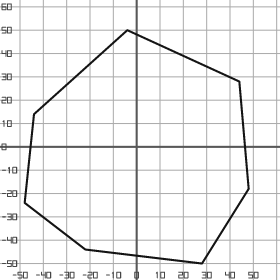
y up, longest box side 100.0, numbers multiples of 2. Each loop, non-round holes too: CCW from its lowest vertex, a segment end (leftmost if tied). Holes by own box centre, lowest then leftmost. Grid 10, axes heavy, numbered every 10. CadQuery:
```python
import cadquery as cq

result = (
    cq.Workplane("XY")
    .moveTo(28.0, -50.0)
    .lineTo(48.0, -18.0)
    .lineTo(44.0, 28.0)
    .lineTo(-4.0, 50.0)
    .lineTo(-44.0, 14.0)
    .lineTo(-48.0, -24.0)
    .lineTo(-22.0, -44.0)
    .close()
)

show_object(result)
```